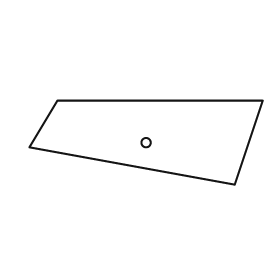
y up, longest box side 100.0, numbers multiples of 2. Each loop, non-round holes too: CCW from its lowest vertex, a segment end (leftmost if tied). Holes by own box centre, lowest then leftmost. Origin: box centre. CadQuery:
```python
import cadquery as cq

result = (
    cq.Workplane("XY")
    .moveTo(38.0, -18.0)
    .lineTo(50.0, 18.0)
    .lineTo(-38.0, 18.0)
    .lineTo(-50.0, -2.0)
    .close()
    .moveTo(0.0, 0.0)
    .circle(2.0)
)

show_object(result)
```